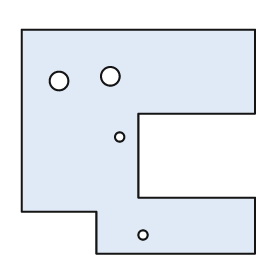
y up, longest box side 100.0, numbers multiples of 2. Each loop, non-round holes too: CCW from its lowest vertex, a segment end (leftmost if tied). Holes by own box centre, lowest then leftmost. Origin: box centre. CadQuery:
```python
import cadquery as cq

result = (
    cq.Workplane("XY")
    .moveTo(-18.0, -48.0)
    .lineTo(50.0, -48.0)
    .lineTo(50.0, -24.0)
    .lineTo(0.0, -24.0)
    .lineTo(0.0, 12.0)
    .lineTo(50.0, 12.0)
    .lineTo(50.0, 48.0)
    .lineTo(-50.0, 48.0)
    .lineTo(-50.0, -30.0)
    .lineTo(-18.0, -30.0)
    .close()
    .moveTo(2.0, -40.0)
    .circle(2.0)
    .moveTo(-8.0, 2.0)
    .circle(2.0)
    .moveTo(-34.0, 26.0)
    .circle(4.0)
    .moveTo(-12.0, 28.0)
    .circle(4.0)
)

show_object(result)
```